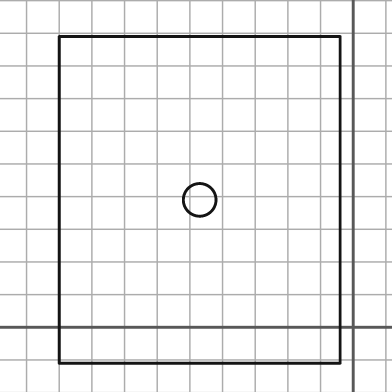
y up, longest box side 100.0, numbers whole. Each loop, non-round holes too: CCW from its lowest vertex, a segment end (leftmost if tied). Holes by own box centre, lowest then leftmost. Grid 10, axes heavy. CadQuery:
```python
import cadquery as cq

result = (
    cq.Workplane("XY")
    .moveTo(-90.0, -11.0)
    .lineTo(-4.0, -11.0)
    .lineTo(-4.0, 89.0)
    .lineTo(-90.0, 89.0)
    .close()
    .moveTo(-47.0, 39.0)
    .circle(5.0)
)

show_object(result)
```